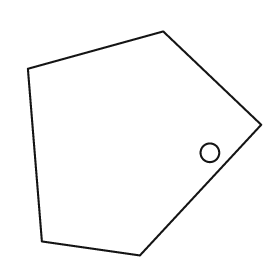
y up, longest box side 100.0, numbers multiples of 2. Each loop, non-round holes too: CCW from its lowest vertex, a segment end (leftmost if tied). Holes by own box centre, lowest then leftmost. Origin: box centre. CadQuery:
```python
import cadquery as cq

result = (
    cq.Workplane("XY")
    .moveTo(-2.0, -48.0)
    .lineTo(50.0, 8.0)
    .lineTo(8.0, 48.0)
    .lineTo(-50.0, 32.0)
    .lineTo(-44.0, -42.0)
    .close()
    .moveTo(28.0, -4.0)
    .circle(4.0)
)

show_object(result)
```